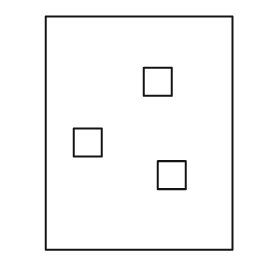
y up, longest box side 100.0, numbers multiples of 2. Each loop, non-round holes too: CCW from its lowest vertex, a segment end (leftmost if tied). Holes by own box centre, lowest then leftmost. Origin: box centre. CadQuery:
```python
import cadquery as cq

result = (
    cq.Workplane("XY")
    .moveTo(-40.0, -50.0)
    .lineTo(40.0, -50.0)
    .lineTo(40.0, 50.0)
    .lineTo(-40.0, 50.0)
    .close()
    .moveTo(8.0, -24.0)
    .lineTo(20.0, -24.0)
    .lineTo(20.0, -12.0)
    .lineTo(8.0, -12.0)
    .close()
    .moveTo(-28.0, -10.0)
    .lineTo(-16.0, -10.0)
    .lineTo(-16.0, 2.0)
    .lineTo(-28.0, 2.0)
    .close()
    .moveTo(2.0, 16.0)
    .lineTo(14.0, 16.0)
    .lineTo(14.0, 28.0)
    .lineTo(2.0, 28.0)
    .close()
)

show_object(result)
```